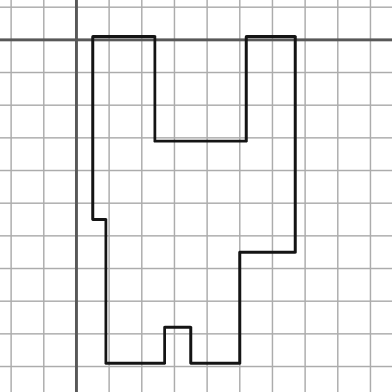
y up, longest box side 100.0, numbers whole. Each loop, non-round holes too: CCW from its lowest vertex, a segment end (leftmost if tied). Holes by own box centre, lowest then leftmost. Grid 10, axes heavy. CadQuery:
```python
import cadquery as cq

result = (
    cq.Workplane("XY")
    .moveTo(9.0, -99.0)
    .lineTo(27.0, -99.0)
    .lineTo(27.0, -88.0)
    .lineTo(35.0, -88.0)
    .lineTo(35.0, -99.0)
    .lineTo(50.0, -99.0)
    .lineTo(50.0, -65.0)
    .lineTo(67.0, -65.0)
    .lineTo(67.0, 1.0)
    .lineTo(52.0, 1.0)
    .lineTo(52.0, -31.0)
    .lineTo(24.0, -31.0)
    .lineTo(24.0, 1.0)
    .lineTo(5.0, 1.0)
    .lineTo(5.0, -55.0)
    .lineTo(9.0, -55.0)
    .close()
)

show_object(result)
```